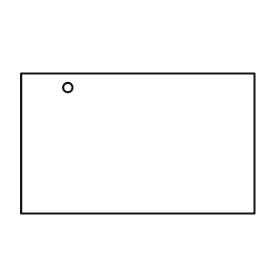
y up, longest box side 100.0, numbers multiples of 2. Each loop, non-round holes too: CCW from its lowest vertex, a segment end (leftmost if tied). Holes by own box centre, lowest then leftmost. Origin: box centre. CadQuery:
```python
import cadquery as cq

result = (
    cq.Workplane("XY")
    .moveTo(-50.0, -30.0)
    .lineTo(50.0, -30.0)
    .lineTo(50.0, 30.0)
    .lineTo(-50.0, 30.0)
    .close()
    .moveTo(-30.0, 24.0)
    .circle(2.0)
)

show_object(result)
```